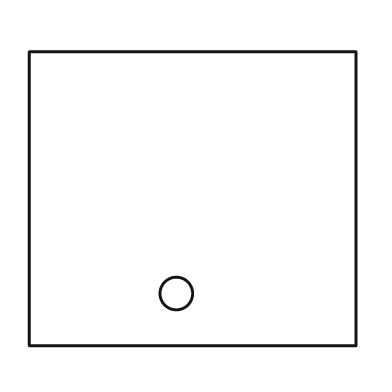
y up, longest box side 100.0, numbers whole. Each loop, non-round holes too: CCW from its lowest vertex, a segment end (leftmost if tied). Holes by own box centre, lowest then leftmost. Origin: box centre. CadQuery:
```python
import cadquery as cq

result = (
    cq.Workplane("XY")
    .moveTo(-50.0, -45.0)
    .lineTo(50.0, -45.0)
    .lineTo(50.0, 45.0)
    .lineTo(-50.0, 45.0)
    .close()
    .moveTo(-5.0, -29.0)
    .circle(5.0)
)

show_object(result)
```